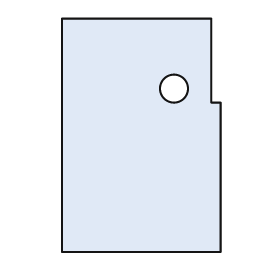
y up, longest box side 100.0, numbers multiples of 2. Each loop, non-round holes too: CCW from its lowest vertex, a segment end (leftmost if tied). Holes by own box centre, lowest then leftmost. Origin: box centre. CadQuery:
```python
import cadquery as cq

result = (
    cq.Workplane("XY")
    .moveTo(-34.0, -50.0)
    .lineTo(34.0, -50.0)
    .lineTo(34.0, 14.0)
    .lineTo(30.0, 14.0)
    .lineTo(30.0, 50.0)
    .lineTo(-34.0, 50.0)
    .close()
    .moveTo(14.0, 20.0)
    .circle(6.0)
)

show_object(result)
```